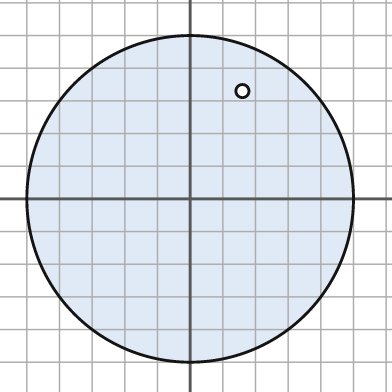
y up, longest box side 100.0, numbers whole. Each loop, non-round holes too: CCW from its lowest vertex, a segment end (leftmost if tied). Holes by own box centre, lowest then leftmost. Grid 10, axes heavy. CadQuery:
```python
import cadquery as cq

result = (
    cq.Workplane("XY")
    .moveTo(0.0, 0.0)
    .circle(50.0)
    .moveTo(16.0, 33.0)
    .circle(2.0)
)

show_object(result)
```